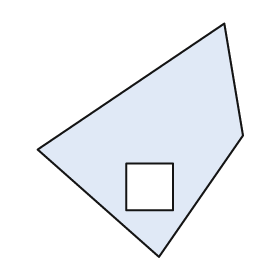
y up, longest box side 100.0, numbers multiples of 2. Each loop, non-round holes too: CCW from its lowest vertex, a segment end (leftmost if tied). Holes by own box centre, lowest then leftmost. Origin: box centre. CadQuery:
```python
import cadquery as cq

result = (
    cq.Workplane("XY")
    .moveTo(8.0, -50.0)
    .lineTo(44.0, 2.0)
    .lineTo(36.0, 50.0)
    .lineTo(-44.0, -4.0)
    .close()
    .moveTo(-6.0, -30.0)
    .lineTo(14.0, -30.0)
    .lineTo(14.0, -10.0)
    .lineTo(-6.0, -10.0)
    .close()
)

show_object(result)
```